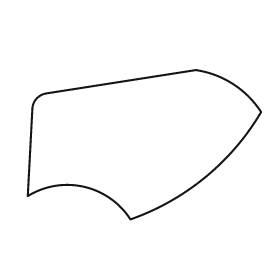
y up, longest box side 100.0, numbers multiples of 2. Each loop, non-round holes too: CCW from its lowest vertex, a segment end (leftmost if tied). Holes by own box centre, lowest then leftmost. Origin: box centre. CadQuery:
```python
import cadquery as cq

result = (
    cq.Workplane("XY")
    .moveTo(-6.0, -32.0)
    .threePointArc((26.0, -14.0), (50.0, 14.0))
    .threePointArc((38.0, 26.0), (22.0, 32.0))
    .lineTo(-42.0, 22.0)
    .threePointArc((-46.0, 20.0), (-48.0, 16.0))
    .lineTo(-50.0, -22.0)
    .threePointArc((-26.0, -18.0), (-6.0, -32.0))
    .close()
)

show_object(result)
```